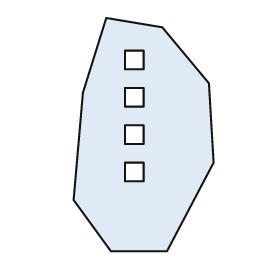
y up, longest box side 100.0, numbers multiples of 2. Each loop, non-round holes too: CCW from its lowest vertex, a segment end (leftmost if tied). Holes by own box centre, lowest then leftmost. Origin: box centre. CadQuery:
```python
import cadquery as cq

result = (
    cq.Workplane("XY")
    .moveTo(-14.0, -50.0)
    .lineTo(10.0, -50.0)
    .lineTo(30.0, -12.0)
    .lineTo(28.0, 22.0)
    .lineTo(8.0, 46.0)
    .lineTo(-16.0, 50.0)
    .lineTo(-26.0, 18.0)
    .lineTo(-30.0, -28.0)
    .close()
    .moveTo(-8.0, -20.0)
    .lineTo(0.0, -20.0)
    .lineTo(0.0, -12.0)
    .lineTo(-8.0, -12.0)
    .close()
    .moveTo(-8.0, -4.0)
    .lineTo(0.0, -4.0)
    .lineTo(0.0, 4.0)
    .lineTo(-8.0, 4.0)
    .close()
    .moveTo(-8.0, 12.0)
    .lineTo(0.0, 12.0)
    .lineTo(0.0, 20.0)
    .lineTo(-8.0, 20.0)
    .close()
    .moveTo(-8.0, 28.0)
    .lineTo(0.0, 28.0)
    .lineTo(0.0, 36.0)
    .lineTo(-8.0, 36.0)
    .close()
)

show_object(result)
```